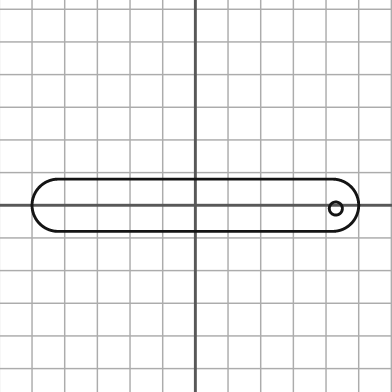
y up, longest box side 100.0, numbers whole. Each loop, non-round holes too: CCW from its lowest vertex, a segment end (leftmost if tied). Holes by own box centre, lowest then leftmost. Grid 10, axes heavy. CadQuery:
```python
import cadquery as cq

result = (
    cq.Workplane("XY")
    .moveTo(-42.0, -8.0)
    .lineTo(42.0, -8.0)
    .threePointArc((50.0, 0.0), (42.0, 8.0))
    .lineTo(-42.0, 8.0)
    .threePointArc((-50.0, 0.0), (-42.0, -8.0))
    .close()
    .moveTo(43.0, -1.0)
    .circle(2.0)
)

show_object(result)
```